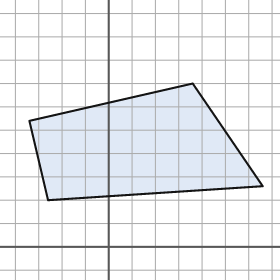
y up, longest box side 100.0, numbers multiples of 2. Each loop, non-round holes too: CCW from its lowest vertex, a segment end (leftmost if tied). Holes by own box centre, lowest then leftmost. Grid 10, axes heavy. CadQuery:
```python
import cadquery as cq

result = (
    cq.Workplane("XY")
    .moveTo(-26.0, 20.0)
    .lineTo(66.0, 26.0)
    .lineTo(36.0, 70.0)
    .lineTo(-34.0, 54.0)
    .close()
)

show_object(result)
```